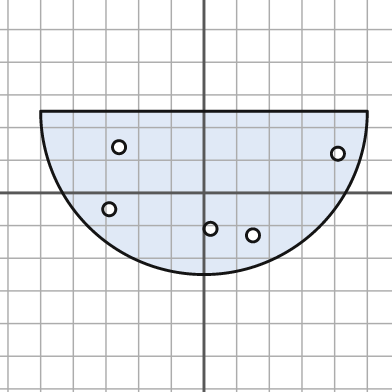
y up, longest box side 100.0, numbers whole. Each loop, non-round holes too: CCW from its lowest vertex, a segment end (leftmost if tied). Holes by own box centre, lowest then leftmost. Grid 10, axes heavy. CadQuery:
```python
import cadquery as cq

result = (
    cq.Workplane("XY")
    .moveTo(-50.0, 25.0)
    .threePointArc((0.0, -25.0), (50.0, 25.0))
    .close()
    .moveTo(15.0, -13.0)
    .circle(2.0)
    .moveTo(2.0, -11.0)
    .circle(2.0)
    .moveTo(-29.0, -5.0)
    .circle(2.0)
    .moveTo(41.0, 12.0)
    .circle(2.0)
    .moveTo(-26.0, 14.0)
    .circle(2.0)
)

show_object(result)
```